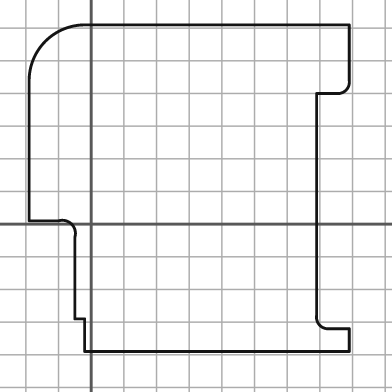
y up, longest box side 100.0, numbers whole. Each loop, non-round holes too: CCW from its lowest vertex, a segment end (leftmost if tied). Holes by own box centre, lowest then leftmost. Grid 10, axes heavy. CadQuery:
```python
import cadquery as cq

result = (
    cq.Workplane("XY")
    .moveTo(-2.0, -39.0)
    .lineTo(79.0, -39.0)
    .lineTo(79.0, -32.0)
    .lineTo(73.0, -32.0)
    .threePointArc((70.0, -31.0), (69.0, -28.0))
    .lineTo(69.0, 40.0)
    .lineTo(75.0, 40.0)
    .threePointArc((78.0, 41.0), (79.0, 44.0))
    .lineTo(79.0, 61.0)
    .lineTo(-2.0, 61.0)
    .threePointArc((-14.0, 56.0), (-19.0, 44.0))
    .lineTo(-19.0, 1.0)
    .lineTo(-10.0, 1.0)
    .threePointArc((-6.0, 0.0), (-5.0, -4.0))
    .lineTo(-5.0, -29.0)
    .lineTo(-2.0, -29.0)
    .close()
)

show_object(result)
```